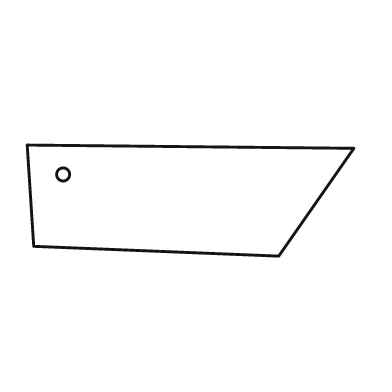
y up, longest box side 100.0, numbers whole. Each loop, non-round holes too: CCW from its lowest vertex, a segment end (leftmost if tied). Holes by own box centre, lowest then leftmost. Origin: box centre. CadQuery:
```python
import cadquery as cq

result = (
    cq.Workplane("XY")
    .moveTo(27.0, -17.0)
    .lineTo(50.0, 16.0)
    .lineTo(-50.0, 17.0)
    .lineTo(-48.0, -14.0)
    .close()
    .moveTo(-39.0, 8.0)
    .circle(2.0)
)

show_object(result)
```